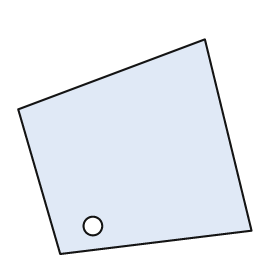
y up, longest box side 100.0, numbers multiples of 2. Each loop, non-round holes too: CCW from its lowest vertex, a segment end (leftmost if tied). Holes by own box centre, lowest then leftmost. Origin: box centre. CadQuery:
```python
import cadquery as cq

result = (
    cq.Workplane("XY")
    .moveTo(-32.0, -46.0)
    .lineTo(50.0, -36.0)
    .lineTo(30.0, 46.0)
    .lineTo(-50.0, 16.0)
    .close()
    .moveTo(-18.0, -34.0)
    .circle(4.0)
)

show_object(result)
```